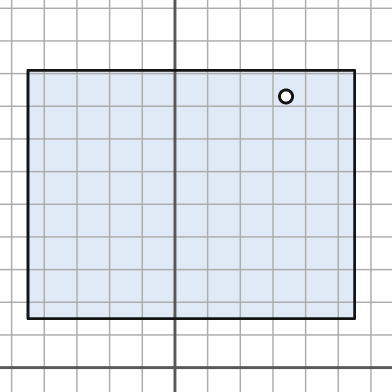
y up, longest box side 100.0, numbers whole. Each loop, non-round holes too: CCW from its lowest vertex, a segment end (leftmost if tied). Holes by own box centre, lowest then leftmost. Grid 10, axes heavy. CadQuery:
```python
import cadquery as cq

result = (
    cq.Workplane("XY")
    .moveTo(-45.0, 15.0)
    .lineTo(55.0, 15.0)
    .lineTo(55.0, 91.0)
    .lineTo(-45.0, 91.0)
    .close()
    .moveTo(34.0, 83.0)
    .circle(2.0)
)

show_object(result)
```